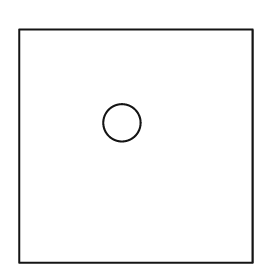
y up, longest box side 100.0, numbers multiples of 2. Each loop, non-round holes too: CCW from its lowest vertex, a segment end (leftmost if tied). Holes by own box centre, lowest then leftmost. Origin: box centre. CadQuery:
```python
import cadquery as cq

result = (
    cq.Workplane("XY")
    .moveTo(-50.0, -50.0)
    .lineTo(50.0, -50.0)
    .lineTo(50.0, 50.0)
    .lineTo(-50.0, 50.0)
    .close()
    .moveTo(-6.0, 10.0)
    .circle(8.0)
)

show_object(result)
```